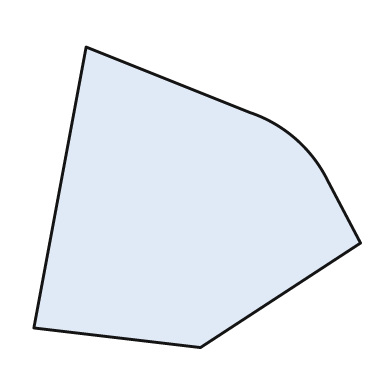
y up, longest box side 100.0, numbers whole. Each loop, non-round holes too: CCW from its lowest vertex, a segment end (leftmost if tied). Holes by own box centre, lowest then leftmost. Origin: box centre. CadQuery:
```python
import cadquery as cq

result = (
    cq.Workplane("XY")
    .moveTo(1.0, -46.0)
    .lineTo(50.0, -14.0)
    .lineTo(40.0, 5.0)
    .threePointArc((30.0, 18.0), (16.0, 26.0))
    .lineTo(-34.0, 46.0)
    .lineTo(-50.0, -40.0)
    .close()
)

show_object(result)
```